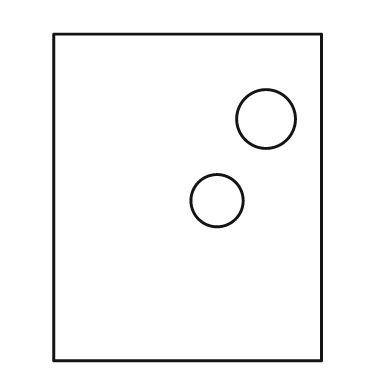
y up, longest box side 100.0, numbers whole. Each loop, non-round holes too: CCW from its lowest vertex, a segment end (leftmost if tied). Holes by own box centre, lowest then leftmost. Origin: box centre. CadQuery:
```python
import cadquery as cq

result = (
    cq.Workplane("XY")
    .moveTo(-41.0, -50.0)
    .lineTo(41.0, -50.0)
    .lineTo(41.0, 50.0)
    .lineTo(-41.0, 50.0)
    .close()
    .moveTo(9.0, -1.0)
    .circle(8.0)
    .moveTo(24.0, 24.0)
    .circle(9.0)
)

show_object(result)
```